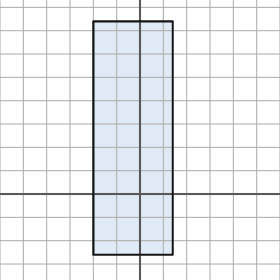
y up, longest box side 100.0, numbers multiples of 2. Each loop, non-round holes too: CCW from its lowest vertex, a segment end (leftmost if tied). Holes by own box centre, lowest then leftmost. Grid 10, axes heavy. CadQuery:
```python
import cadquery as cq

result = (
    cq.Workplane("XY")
    .moveTo(-20.0, -26.0)
    .lineTo(14.0, -26.0)
    .lineTo(14.0, 74.0)
    .lineTo(-20.0, 74.0)
    .close()
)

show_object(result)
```